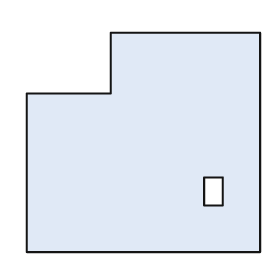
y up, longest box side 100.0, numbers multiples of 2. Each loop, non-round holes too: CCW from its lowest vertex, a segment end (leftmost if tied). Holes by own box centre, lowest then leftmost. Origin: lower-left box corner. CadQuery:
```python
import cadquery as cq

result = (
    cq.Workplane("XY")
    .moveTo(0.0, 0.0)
    .lineTo(100.0, 0.0)
    .lineTo(100.0, 94.0)
    .lineTo(36.0, 94.0)
    .lineTo(36.0, 68.0)
    .lineTo(0.0, 68.0)
    .close()
    .moveTo(76.0, 20.0)
    .lineTo(84.0, 20.0)
    .lineTo(84.0, 32.0)
    .lineTo(76.0, 32.0)
    .close()
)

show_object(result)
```